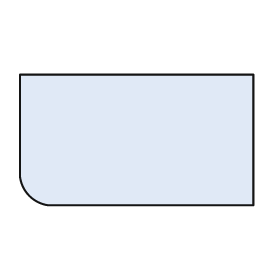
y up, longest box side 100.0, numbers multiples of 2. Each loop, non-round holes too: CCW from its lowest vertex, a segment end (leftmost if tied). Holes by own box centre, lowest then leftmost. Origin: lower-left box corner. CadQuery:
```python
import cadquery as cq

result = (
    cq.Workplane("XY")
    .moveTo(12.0, 0.0)
    .lineTo(100.0, 0.0)
    .lineTo(100.0, 56.0)
    .lineTo(0.0, 56.0)
    .lineTo(0.0, 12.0)
    .threePointArc((4.0, 4.0), (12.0, 0.0))
    .close()
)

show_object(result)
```